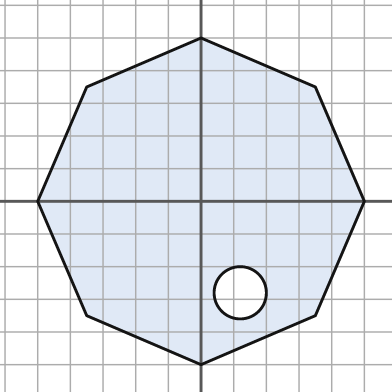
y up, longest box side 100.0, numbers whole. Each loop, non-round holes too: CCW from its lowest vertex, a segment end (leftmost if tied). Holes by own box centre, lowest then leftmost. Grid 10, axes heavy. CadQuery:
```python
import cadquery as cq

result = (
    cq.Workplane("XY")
    .moveTo(0.0, -50.0)
    .lineTo(35.0, -35.0)
    .lineTo(50.0, 0.0)
    .lineTo(35.0, 35.0)
    .lineTo(0.0, 50.0)
    .lineTo(-35.0, 35.0)
    .lineTo(-50.0, 0.0)
    .lineTo(-35.0, -35.0)
    .close()
    .moveTo(12.0, -28.0)
    .circle(8.0)
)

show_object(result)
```